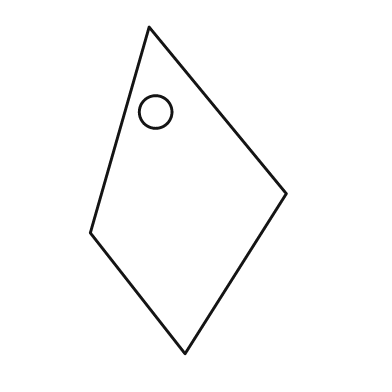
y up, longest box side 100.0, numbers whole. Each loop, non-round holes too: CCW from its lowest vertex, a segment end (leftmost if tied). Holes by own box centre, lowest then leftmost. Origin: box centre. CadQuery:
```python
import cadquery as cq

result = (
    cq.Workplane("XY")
    .moveTo(-1.0, -50.0)
    .lineTo(30.0, -1.0)
    .lineTo(-12.0, 50.0)
    .lineTo(-30.0, -13.0)
    .close()
    .moveTo(-10.0, 24.0)
    .circle(5.0)
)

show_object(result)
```